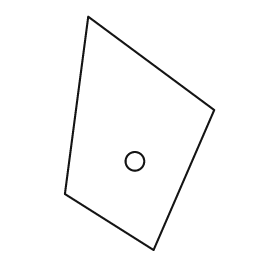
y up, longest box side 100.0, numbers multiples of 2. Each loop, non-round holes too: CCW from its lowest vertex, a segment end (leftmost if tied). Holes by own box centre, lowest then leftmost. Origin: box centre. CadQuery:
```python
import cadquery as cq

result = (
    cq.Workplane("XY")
    .moveTo(6.0, -50.0)
    .lineTo(32.0, 10.0)
    .lineTo(-22.0, 50.0)
    .lineTo(-32.0, -26.0)
    .close()
    .moveTo(-2.0, -12.0)
    .circle(4.0)
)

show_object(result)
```